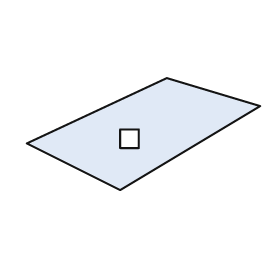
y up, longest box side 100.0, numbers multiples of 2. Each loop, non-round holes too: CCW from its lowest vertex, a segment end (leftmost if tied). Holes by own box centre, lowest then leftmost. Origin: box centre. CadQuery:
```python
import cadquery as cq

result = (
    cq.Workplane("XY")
    .moveTo(-10.0, -24.0)
    .lineTo(50.0, 12.0)
    .lineTo(10.0, 24.0)
    .lineTo(-50.0, -4.0)
    .close()
    .moveTo(-10.0, -6.0)
    .lineTo(-2.0, -6.0)
    .lineTo(-2.0, 2.0)
    .lineTo(-10.0, 2.0)
    .close()
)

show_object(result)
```